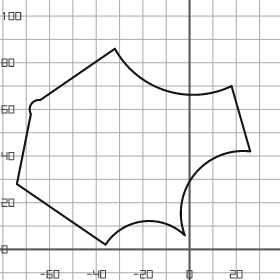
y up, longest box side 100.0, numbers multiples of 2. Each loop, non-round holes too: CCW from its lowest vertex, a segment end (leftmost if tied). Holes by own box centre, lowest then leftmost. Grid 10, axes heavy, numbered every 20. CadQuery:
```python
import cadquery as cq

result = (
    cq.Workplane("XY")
    .moveTo(-36.0, 2.0)
    .threePointArc((-20.0, 12.0), (-2.0, 6.0))
    .threePointArc((2.0, 32.0), (26.0, 42.0))
    .lineTo(18.0, 70.0)
    .threePointArc((-10.0, 68.0), (-32.0, 86.0))
    .lineTo(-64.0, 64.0)
    .threePointArc((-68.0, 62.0), (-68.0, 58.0))
    .lineTo(-74.0, 28.0)
    .close()
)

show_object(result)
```